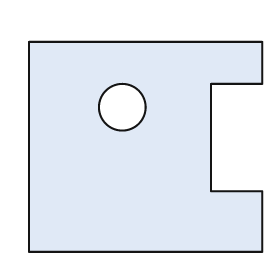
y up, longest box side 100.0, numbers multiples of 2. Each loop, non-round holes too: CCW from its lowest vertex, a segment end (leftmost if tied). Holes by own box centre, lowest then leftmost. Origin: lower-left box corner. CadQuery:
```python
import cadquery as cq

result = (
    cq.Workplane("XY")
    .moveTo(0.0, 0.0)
    .lineTo(100.0, 0.0)
    .lineTo(100.0, 26.0)
    .lineTo(78.0, 26.0)
    .lineTo(78.0, 72.0)
    .lineTo(100.0, 72.0)
    .lineTo(100.0, 90.0)
    .lineTo(0.0, 90.0)
    .close()
    .moveTo(40.0, 62.0)
    .circle(10.0)
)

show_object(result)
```